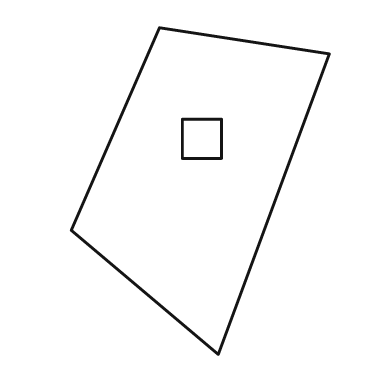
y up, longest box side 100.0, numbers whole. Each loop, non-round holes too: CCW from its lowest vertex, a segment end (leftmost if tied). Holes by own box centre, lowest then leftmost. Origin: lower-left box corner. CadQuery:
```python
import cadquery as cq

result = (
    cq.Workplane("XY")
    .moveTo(45.0, 0.0)
    .lineTo(79.0, 92.0)
    .lineTo(27.0, 100.0)
    .lineTo(0.0, 38.0)
    .close()
    .moveTo(34.0, 60.0)
    .lineTo(46.0, 60.0)
    .lineTo(46.0, 72.0)
    .lineTo(34.0, 72.0)
    .close()
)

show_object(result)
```